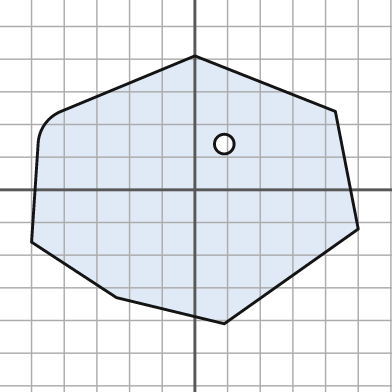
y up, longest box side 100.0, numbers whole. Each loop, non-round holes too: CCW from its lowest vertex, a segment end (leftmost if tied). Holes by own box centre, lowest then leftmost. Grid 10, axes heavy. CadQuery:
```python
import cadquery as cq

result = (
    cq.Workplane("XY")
    .moveTo(9.0, -41.0)
    .lineTo(50.0, -12.0)
    .lineTo(43.0, 24.0)
    .lineTo(0.0, 41.0)
    .lineTo(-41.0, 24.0)
    .threePointArc((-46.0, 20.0), (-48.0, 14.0))
    .lineTo(-50.0, -16.0)
    .lineTo(-24.0, -33.0)
    .close()
    .moveTo(9.0, 14.0)
    .circle(3.0)
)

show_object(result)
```